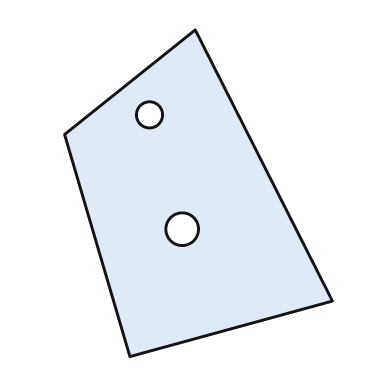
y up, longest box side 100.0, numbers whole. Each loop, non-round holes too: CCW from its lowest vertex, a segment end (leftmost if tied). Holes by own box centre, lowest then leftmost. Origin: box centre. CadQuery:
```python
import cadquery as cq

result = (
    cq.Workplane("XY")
    .moveTo(-21.0, -50.0)
    .lineTo(41.0, -33.0)
    .lineTo(-1.0, 50.0)
    .lineTo(-41.0, 18.0)
    .close()
    .moveTo(-5.0, -11.0)
    .circle(5.0)
    .moveTo(-15.0, 24.0)
    .circle(4.0)
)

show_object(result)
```